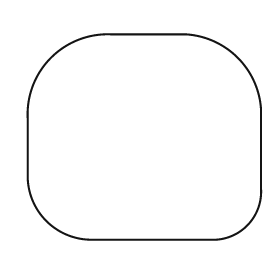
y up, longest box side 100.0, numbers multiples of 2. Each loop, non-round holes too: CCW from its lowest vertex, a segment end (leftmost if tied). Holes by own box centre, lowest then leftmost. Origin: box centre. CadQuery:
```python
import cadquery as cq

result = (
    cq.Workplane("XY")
    .moveTo(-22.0, -44.0)
    .lineTo(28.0, -44.0)
    .threePointArc((44.0, -38.0), (50.0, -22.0))
    .lineTo(50.0, 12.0)
    .threePointArc((40.0, 34.0), (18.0, 44.0))
    .lineTo(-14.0, 44.0)
    .threePointArc((-40.0, 34.0), (-50.0, 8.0))
    .lineTo(-50.0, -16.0)
    .threePointArc((-42.0, -36.0), (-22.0, -44.0))
    .close()
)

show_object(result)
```